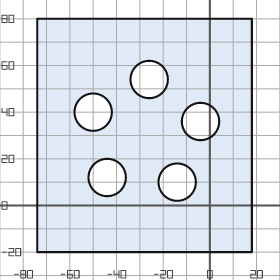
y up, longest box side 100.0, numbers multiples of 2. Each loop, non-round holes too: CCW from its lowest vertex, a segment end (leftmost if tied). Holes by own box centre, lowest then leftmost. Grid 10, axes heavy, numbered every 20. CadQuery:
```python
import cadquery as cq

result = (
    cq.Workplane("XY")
    .moveTo(-74.0, -20.0)
    .lineTo(18.0, -20.0)
    .lineTo(18.0, 80.0)
    .lineTo(-74.0, 80.0)
    .close()
    .moveTo(-14.0, 10.0)
    .circle(8.0)
    .moveTo(-44.0, 12.0)
    .circle(8.0)
    .moveTo(-4.0, 36.0)
    .circle(8.0)
    .moveTo(-50.0, 40.0)
    .circle(8.0)
    .moveTo(-26.0, 54.0)
    .circle(8.0)
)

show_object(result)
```